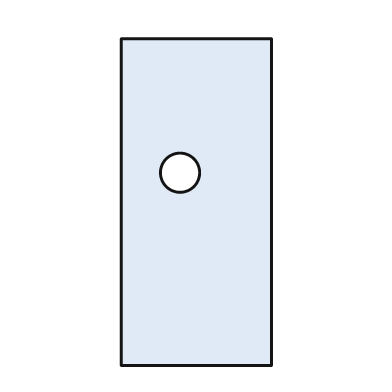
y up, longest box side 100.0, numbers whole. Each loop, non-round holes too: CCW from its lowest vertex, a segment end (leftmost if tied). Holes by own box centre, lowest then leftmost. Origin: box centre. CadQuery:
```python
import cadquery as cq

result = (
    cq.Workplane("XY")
    .moveTo(-23.0, -50.0)
    .lineTo(23.0, -50.0)
    .lineTo(23.0, 50.0)
    .lineTo(-23.0, 50.0)
    .close()
    .moveTo(-5.0, 9.0)
    .circle(6.0)
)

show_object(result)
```